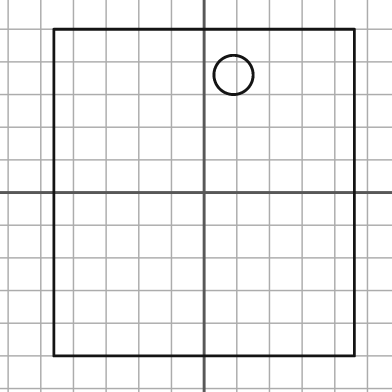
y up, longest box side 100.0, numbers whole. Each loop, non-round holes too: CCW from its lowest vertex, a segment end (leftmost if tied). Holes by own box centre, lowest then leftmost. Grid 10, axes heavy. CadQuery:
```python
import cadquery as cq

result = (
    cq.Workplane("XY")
    .moveTo(-46.0, -50.0)
    .lineTo(46.0, -50.0)
    .lineTo(46.0, 50.0)
    .lineTo(-46.0, 50.0)
    .close()
    .moveTo(9.0, 36.0)
    .circle(6.0)
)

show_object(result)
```